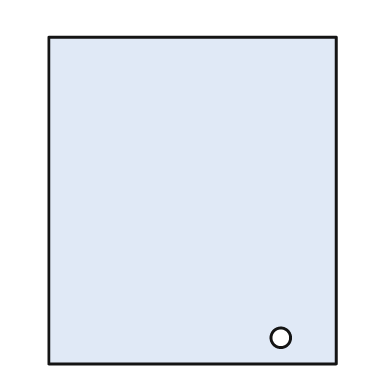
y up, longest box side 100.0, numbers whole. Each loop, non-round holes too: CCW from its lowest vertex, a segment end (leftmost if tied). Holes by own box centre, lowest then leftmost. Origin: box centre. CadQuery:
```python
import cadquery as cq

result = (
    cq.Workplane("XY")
    .moveTo(-44.0, -50.0)
    .lineTo(44.0, -50.0)
    .lineTo(44.0, 50.0)
    .lineTo(-44.0, 50.0)
    .close()
    .moveTo(27.0, -42.0)
    .circle(3.0)
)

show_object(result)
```